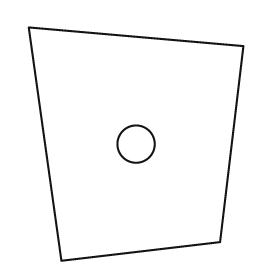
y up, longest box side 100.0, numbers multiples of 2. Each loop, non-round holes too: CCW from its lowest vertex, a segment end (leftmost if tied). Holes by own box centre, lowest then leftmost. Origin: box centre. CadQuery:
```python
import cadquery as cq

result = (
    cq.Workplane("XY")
    .moveTo(-32.0, -50.0)
    .lineTo(36.0, -42.0)
    .lineTo(46.0, 42.0)
    .lineTo(-46.0, 50.0)
    .close()
    .moveTo(0.0, 0.0)
    .circle(8.0)
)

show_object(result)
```